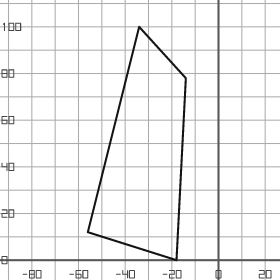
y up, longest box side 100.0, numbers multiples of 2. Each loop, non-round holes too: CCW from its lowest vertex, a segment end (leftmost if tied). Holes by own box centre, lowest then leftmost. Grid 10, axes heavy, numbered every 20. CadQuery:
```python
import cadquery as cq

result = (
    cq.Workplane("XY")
    .moveTo(-18.0, 0.0)
    .lineTo(-14.0, 78.0)
    .lineTo(-34.0, 100.0)
    .lineTo(-56.0, 12.0)
    .close()
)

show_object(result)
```